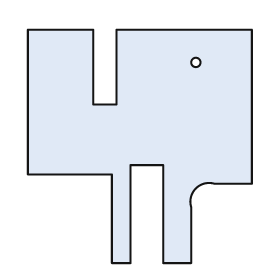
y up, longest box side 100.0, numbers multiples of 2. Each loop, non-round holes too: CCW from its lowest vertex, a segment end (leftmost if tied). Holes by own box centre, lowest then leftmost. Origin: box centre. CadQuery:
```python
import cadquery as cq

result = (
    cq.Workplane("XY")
    .moveTo(-12.0, -50.0)
    .lineTo(-4.0, -50.0)
    .lineTo(-4.0, -8.0)
    .lineTo(10.0, -8.0)
    .lineTo(10.0, -50.0)
    .lineTo(22.0, -50.0)
    .lineTo(22.0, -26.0)
    .threePointArc((24.0, -18.0), (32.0, -16.0))
    .lineTo(48.0, -16.0)
    .lineTo(48.0, 50.0)
    .lineTo(-10.0, 50.0)
    .lineTo(-10.0, 18.0)
    .lineTo(-20.0, 18.0)
    .lineTo(-20.0, 50.0)
    .lineTo(-48.0, 50.0)
    .lineTo(-48.0, -12.0)
    .lineTo(-12.0, -12.0)
    .close()
    .moveTo(24.0, 36.0)
    .circle(2.0)
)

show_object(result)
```